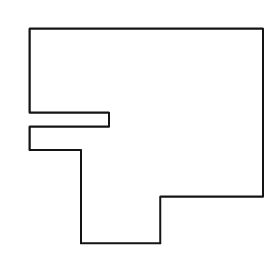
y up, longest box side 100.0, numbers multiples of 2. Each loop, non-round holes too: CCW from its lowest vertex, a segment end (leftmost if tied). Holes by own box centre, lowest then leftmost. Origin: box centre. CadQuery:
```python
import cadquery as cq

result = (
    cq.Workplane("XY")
    .moveTo(-28.0, -46.0)
    .lineTo(6.0, -46.0)
    .lineTo(6.0, -26.0)
    .lineTo(50.0, -26.0)
    .lineTo(50.0, 46.0)
    .lineTo(-50.0, 46.0)
    .lineTo(-50.0, 10.0)
    .lineTo(-16.0, 10.0)
    .lineTo(-16.0, 4.0)
    .lineTo(-50.0, 4.0)
    .lineTo(-50.0, -6.0)
    .lineTo(-28.0, -6.0)
    .close()
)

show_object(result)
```